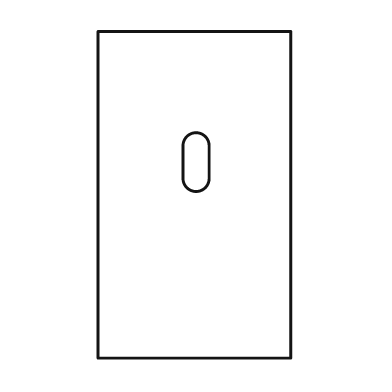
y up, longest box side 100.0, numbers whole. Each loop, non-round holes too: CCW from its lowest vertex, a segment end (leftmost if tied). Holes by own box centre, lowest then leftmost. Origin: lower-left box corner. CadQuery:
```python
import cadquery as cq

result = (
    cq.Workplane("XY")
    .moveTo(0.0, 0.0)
    .lineTo(59.0, 0.0)
    .lineTo(59.0, 100.0)
    .lineTo(0.0, 100.0)
    .close()
    .moveTo(26.0, 55.0)
    .threePointArc((30.0, 51.0), (34.0, 55.0))
    .lineTo(34.0, 65.0)
    .threePointArc((30.0, 69.0), (26.0, 65.0))
    .close()
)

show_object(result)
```